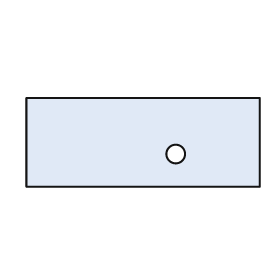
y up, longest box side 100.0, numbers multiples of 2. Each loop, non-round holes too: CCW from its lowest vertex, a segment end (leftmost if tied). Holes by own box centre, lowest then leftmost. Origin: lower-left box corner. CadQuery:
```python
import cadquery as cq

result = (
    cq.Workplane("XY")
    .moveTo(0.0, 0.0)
    .lineTo(100.0, 0.0)
    .lineTo(100.0, 38.0)
    .lineTo(0.0, 38.0)
    .close()
    .moveTo(64.0, 14.0)
    .circle(4.0)
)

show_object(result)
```